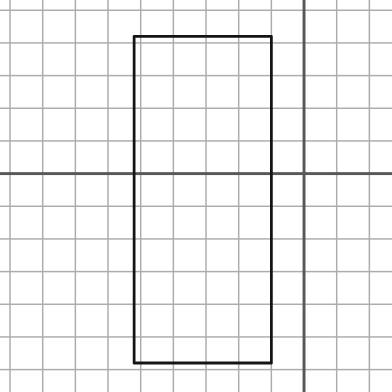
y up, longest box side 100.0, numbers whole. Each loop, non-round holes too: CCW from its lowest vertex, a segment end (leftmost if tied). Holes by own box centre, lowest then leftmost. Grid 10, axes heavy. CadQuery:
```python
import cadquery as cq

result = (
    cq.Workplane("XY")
    .moveTo(-52.0, -58.0)
    .lineTo(-10.0, -58.0)
    .lineTo(-10.0, 42.0)
    .lineTo(-52.0, 42.0)
    .close()
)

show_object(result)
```